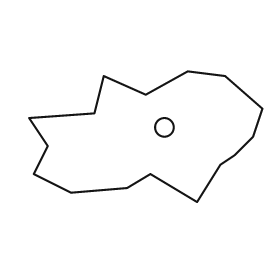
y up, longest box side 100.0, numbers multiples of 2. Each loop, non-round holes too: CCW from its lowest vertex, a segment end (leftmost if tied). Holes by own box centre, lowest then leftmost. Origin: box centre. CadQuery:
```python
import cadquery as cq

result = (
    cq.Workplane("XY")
    .moveTo(22.0, -28.0)
    .lineTo(32.0, -12.0)
    .lineTo(38.0, -8.0)
    .lineTo(46.0, 0.0)
    .lineTo(50.0, 12.0)
    .lineTo(34.0, 26.0)
    .lineTo(18.0, 28.0)
    .lineTo(0.0, 18.0)
    .lineTo(-18.0, 26.0)
    .lineTo(-22.0, 10.0)
    .lineTo(-50.0, 8.0)
    .lineTo(-42.0, -4.0)
    .lineTo(-48.0, -16.0)
    .lineTo(-32.0, -24.0)
    .lineTo(-8.0, -22.0)
    .lineTo(2.0, -16.0)
    .close()
    .moveTo(8.0, 4.0)
    .circle(4.0)
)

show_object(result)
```